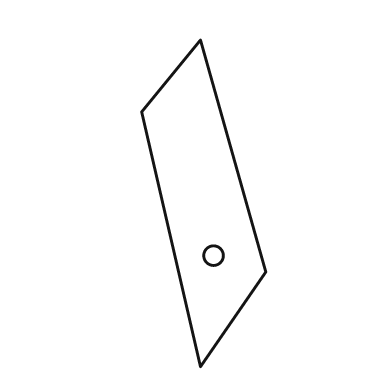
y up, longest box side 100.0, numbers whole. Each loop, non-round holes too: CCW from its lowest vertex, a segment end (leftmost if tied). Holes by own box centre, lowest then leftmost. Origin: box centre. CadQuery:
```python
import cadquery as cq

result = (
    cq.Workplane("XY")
    .moveTo(-1.0, -50.0)
    .lineTo(19.0, -21.0)
    .lineTo(-1.0, 50.0)
    .lineTo(-19.0, 28.0)
    .close()
    .moveTo(3.0, -16.0)
    .circle(3.0)
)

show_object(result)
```